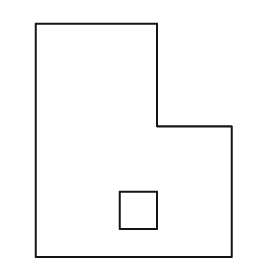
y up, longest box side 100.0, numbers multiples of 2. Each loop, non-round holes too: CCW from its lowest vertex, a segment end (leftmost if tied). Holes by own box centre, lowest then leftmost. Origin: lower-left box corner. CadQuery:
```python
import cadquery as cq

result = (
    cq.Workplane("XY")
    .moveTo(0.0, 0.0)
    .lineTo(84.0, 0.0)
    .lineTo(84.0, 56.0)
    .lineTo(52.0, 56.0)
    .lineTo(52.0, 100.0)
    .lineTo(0.0, 100.0)
    .close()
    .moveTo(36.0, 12.0)
    .lineTo(52.0, 12.0)
    .lineTo(52.0, 28.0)
    .lineTo(36.0, 28.0)
    .close()
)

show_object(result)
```